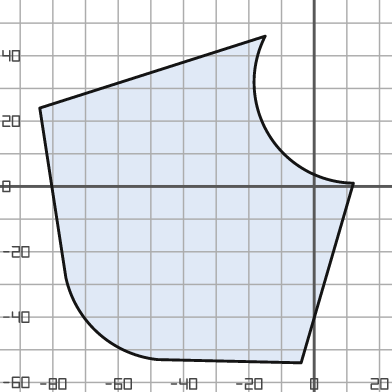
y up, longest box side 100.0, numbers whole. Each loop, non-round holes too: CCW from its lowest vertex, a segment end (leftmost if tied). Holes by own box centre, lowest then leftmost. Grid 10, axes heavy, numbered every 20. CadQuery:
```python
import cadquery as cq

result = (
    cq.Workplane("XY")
    .moveTo(-4.0, -54.0)
    .lineTo(12.0, 1.0)
    .threePointArc((-14.0, 16.0), (-15.0, 46.0))
    .lineTo(-84.0, 24.0)
    .lineTo(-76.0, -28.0)
    .threePointArc((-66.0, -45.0), (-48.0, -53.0))
    .close()
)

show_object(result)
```